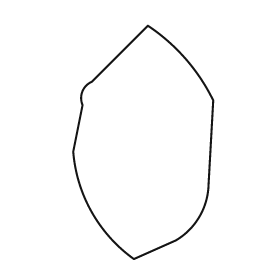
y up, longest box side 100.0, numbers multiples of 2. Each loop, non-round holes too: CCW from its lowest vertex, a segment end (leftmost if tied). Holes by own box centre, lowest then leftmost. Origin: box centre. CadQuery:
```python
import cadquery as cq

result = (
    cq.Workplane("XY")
    .moveTo(-4.0, -50.0)
    .lineTo(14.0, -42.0)
    .threePointArc((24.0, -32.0), (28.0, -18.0))
    .lineTo(30.0, 18.0)
    .threePointArc((18.0, 36.0), (2.0, 50.0))
    .lineTo(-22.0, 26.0)
    .threePointArc((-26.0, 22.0), (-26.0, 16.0))
    .lineTo(-30.0, -4.0)
    .threePointArc((-22.0, -30.0), (-4.0, -50.0))
    .close()
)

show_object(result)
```